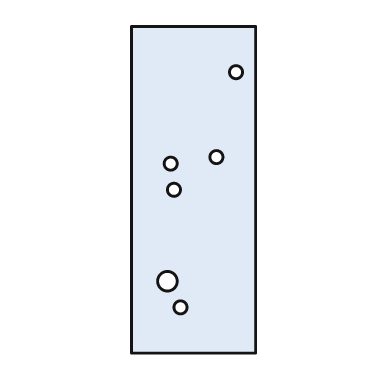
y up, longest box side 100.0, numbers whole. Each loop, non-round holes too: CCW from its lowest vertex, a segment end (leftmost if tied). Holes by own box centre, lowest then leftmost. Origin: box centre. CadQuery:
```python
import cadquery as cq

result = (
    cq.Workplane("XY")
    .moveTo(-19.0, -50.0)
    .lineTo(19.0, -50.0)
    .lineTo(19.0, 50.0)
    .lineTo(-19.0, 50.0)
    .close()
    .moveTo(-4.0, -36.0)
    .circle(2.0)
    .moveTo(-8.0, -28.0)
    .circle(3.0)
    .moveTo(-6.0, 0.0)
    .circle(2.0)
    .moveTo(-7.0, 8.0)
    .circle(2.0)
    .moveTo(7.0, 10.0)
    .circle(2.0)
    .moveTo(13.0, 36.0)
    .circle(2.0)
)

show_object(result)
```